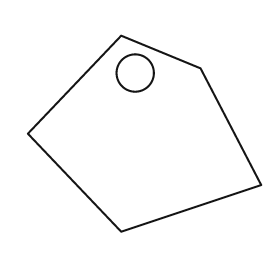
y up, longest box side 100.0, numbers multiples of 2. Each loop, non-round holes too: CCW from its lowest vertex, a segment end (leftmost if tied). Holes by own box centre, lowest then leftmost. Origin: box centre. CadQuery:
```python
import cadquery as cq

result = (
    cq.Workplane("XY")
    .moveTo(-10.0, -42.0)
    .lineTo(50.0, -22.0)
    .lineTo(24.0, 28.0)
    .lineTo(-10.0, 42.0)
    .lineTo(-50.0, 0.0)
    .close()
    .moveTo(-4.0, 26.0)
    .circle(8.0)
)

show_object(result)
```